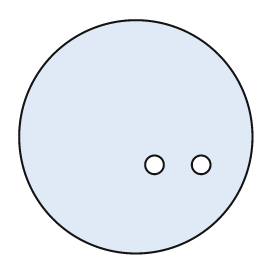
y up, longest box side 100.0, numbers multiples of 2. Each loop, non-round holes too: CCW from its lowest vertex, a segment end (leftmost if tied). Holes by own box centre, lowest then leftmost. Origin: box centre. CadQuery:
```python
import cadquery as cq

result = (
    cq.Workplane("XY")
    .moveTo(0.0, 0.0)
    .circle(50.0)
    .moveTo(8.0, -12.0)
    .circle(4.0)
    .moveTo(28.0, -12.0)
    .circle(4.0)
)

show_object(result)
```